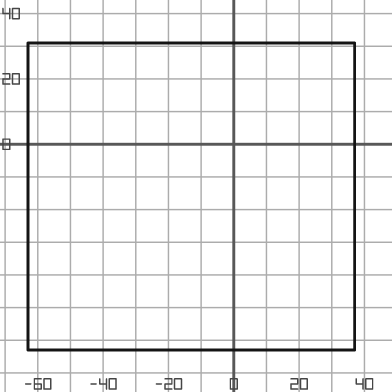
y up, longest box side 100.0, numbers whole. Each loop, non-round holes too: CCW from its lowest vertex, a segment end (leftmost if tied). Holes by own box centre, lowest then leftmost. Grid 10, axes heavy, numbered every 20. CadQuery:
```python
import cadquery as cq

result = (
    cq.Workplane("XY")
    .moveTo(-63.0, -63.0)
    .lineTo(37.0, -63.0)
    .lineTo(37.0, 31.0)
    .lineTo(-63.0, 31.0)
    .close()
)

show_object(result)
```